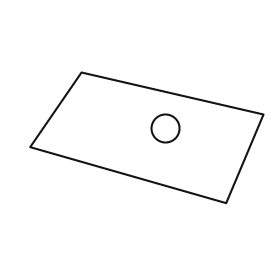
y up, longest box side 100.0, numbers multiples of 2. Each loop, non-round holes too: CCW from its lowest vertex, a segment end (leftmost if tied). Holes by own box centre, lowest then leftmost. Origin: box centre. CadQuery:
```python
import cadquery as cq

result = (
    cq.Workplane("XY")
    .moveTo(34.0, -28.0)
    .lineTo(50.0, 10.0)
    .lineTo(-28.0, 28.0)
    .lineTo(-50.0, -4.0)
    .close()
    .moveTo(8.0, 4.0)
    .circle(6.0)
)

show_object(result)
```